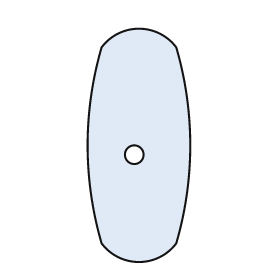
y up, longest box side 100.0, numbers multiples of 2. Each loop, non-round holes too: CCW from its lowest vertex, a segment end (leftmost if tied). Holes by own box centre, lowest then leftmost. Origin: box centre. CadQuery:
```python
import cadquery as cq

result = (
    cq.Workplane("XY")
    .moveTo(-16.0, -42.0)
    .threePointArc((0.0, -50.0), (16.0, -42.0))
    .threePointArc((22.0, 0.0), (16.0, 42.0))
    .threePointArc((0.0, 50.0), (-16.0, 42.0))
    .threePointArc((-22.0, 0.0), (-16.0, -42.0))
    .close()
    .moveTo(-2.0, -4.0)
    .circle(4.0)
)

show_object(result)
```